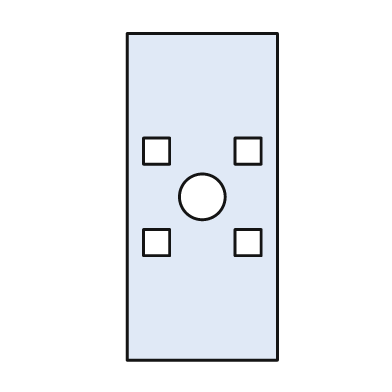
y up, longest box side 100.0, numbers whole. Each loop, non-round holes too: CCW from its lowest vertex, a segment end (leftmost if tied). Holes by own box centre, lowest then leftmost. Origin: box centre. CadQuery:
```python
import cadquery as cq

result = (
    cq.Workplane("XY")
    .moveTo(-23.0, -50.0)
    .lineTo(23.0, -50.0)
    .lineTo(23.0, 50.0)
    .lineTo(-23.0, 50.0)
    .close()
    .moveTo(-18.0, -18.0)
    .lineTo(-10.0, -18.0)
    .lineTo(-10.0, -10.0)
    .lineTo(-18.0, -10.0)
    .close()
    .moveTo(10.0, -18.0)
    .lineTo(18.0, -18.0)
    .lineTo(18.0, -10.0)
    .lineTo(10.0, -10.0)
    .close()
    .moveTo(0.0, 0.0)
    .circle(7.0)
    .moveTo(-18.0, 10.0)
    .lineTo(-10.0, 10.0)
    .lineTo(-10.0, 18.0)
    .lineTo(-18.0, 18.0)
    .close()
    .moveTo(10.0, 10.0)
    .lineTo(18.0, 10.0)
    .lineTo(18.0, 18.0)
    .lineTo(10.0, 18.0)
    .close()
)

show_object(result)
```